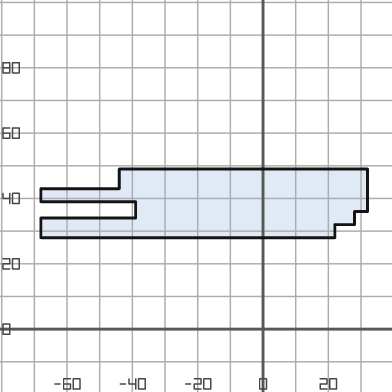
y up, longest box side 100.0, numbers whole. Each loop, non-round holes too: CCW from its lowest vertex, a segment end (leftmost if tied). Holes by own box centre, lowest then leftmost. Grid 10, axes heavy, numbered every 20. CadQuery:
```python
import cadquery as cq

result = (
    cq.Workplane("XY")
    .moveTo(-68.0, 28.0)
    .lineTo(22.0, 28.0)
    .lineTo(22.0, 32.0)
    .lineTo(28.0, 32.0)
    .lineTo(28.0, 36.0)
    .lineTo(32.0, 36.0)
    .lineTo(32.0, 49.0)
    .lineTo(-44.0, 49.0)
    .lineTo(-44.0, 43.0)
    .lineTo(-68.0, 43.0)
    .lineTo(-68.0, 39.0)
    .lineTo(-39.0, 39.0)
    .lineTo(-39.0, 34.0)
    .lineTo(-68.0, 34.0)
    .close()
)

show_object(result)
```